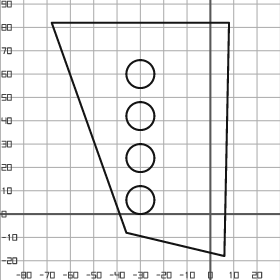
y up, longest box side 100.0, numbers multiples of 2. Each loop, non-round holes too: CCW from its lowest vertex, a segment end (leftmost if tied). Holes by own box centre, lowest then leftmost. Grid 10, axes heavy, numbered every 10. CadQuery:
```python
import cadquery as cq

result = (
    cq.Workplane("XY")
    .moveTo(6.0, -18.0)
    .lineTo(8.0, 82.0)
    .lineTo(-68.0, 82.0)
    .lineTo(-36.0, -8.0)
    .close()
    .moveTo(-30.0, 6.0)
    .circle(6.0)
    .moveTo(-30.0, 24.0)
    .circle(6.0)
    .moveTo(-30.0, 42.0)
    .circle(6.0)
    .moveTo(-30.0, 60.0)
    .circle(6.0)
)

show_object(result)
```